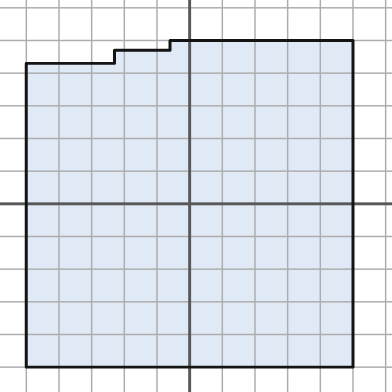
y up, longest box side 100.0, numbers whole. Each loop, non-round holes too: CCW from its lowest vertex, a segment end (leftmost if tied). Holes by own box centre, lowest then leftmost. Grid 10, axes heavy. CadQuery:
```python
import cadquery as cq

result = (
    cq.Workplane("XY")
    .moveTo(-50.0, -50.0)
    .lineTo(50.0, -50.0)
    .lineTo(50.0, 50.0)
    .lineTo(-6.0, 50.0)
    .lineTo(-6.0, 47.0)
    .lineTo(-23.0, 47.0)
    .lineTo(-23.0, 43.0)
    .lineTo(-50.0, 43.0)
    .close()
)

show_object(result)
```